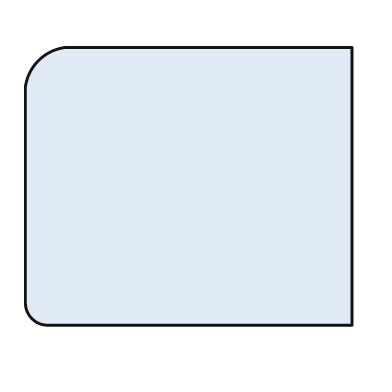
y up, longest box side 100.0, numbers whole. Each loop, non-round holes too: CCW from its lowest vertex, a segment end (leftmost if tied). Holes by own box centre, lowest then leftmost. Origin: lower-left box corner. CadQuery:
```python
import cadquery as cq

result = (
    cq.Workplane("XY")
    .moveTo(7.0, 0.0)
    .lineTo(100.0, 0.0)
    .lineTo(100.0, 85.0)
    .lineTo(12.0, 85.0)
    .threePointArc((4.0, 81.0), (0.0, 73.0))
    .lineTo(0.0, 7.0)
    .threePointArc((2.0, 2.0), (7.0, 0.0))
    .close()
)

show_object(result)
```